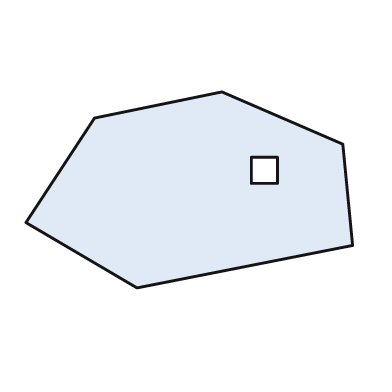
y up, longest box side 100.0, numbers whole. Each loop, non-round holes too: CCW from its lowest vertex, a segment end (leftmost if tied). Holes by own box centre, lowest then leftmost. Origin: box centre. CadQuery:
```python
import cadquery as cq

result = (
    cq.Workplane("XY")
    .moveTo(-16.0, -30.0)
    .lineTo(50.0, -17.0)
    .lineTo(47.0, 14.0)
    .lineTo(10.0, 30.0)
    .lineTo(-29.0, 22.0)
    .lineTo(-50.0, -10.0)
    .close()
    .moveTo(19.0, 2.0)
    .lineTo(27.0, 2.0)
    .lineTo(27.0, 10.0)
    .lineTo(19.0, 10.0)
    .close()
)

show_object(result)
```